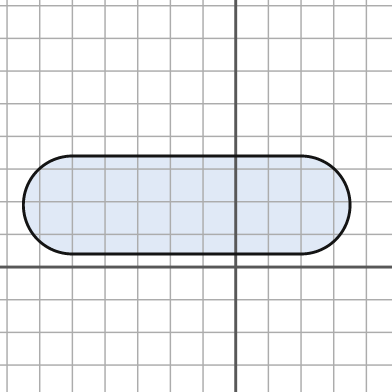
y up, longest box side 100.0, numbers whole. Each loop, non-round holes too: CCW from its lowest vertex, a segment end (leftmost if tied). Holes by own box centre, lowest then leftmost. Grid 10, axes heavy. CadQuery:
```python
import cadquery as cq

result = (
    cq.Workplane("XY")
    .moveTo(-50.0, 4.0)
    .lineTo(20.0, 4.0)
    .threePointArc((35.0, 19.0), (20.0, 34.0))
    .lineTo(-50.0, 34.0)
    .threePointArc((-65.0, 19.0), (-50.0, 4.0))
    .close()
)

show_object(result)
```